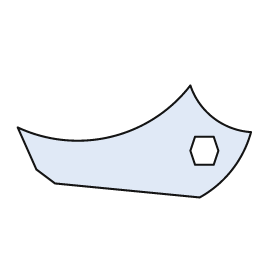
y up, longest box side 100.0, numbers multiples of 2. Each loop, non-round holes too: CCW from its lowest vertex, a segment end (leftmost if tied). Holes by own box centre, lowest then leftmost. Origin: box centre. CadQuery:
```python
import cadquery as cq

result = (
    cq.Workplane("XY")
    .moveTo(28.0, -24.0)
    .threePointArc((42.0, -12.0), (50.0, 4.0))
    .threePointArc((34.0, 10.0), (24.0, 24.0))
    .threePointArc((-10.0, 2.0), (-50.0, 6.0))
    .lineTo(-42.0, -12.0)
    .lineTo(-34.0, -18.0)
    .close()
    .moveTo(26.0, -10.0)
    .lineTo(34.0, -10.0)
    .lineTo(36.0, -4.0)
    .lineTo(34.0, 2.0)
    .lineTo(26.0, 2.0)
    .lineTo(24.0, -4.0)
    .close()
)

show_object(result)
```